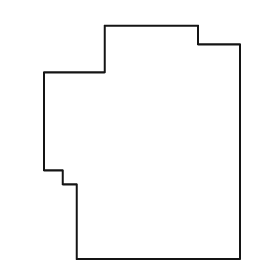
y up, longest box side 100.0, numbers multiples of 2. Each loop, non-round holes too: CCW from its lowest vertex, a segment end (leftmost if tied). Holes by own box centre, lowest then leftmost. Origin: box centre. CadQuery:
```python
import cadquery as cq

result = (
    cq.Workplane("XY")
    .moveTo(-28.0, -50.0)
    .lineTo(42.0, -50.0)
    .lineTo(42.0, 42.0)
    .lineTo(24.0, 42.0)
    .lineTo(24.0, 50.0)
    .lineTo(-16.0, 50.0)
    .lineTo(-16.0, 30.0)
    .lineTo(-42.0, 30.0)
    .lineTo(-42.0, -12.0)
    .lineTo(-34.0, -12.0)
    .lineTo(-34.0, -18.0)
    .lineTo(-28.0, -18.0)
    .close()
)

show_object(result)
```